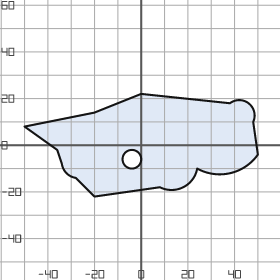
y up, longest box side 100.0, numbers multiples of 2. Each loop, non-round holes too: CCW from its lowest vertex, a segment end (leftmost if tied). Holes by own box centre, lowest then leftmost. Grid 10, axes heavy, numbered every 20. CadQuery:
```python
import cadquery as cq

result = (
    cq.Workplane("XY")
    .moveTo(-20.0, -22.0)
    .lineTo(8.0, -18.0)
    .threePointArc((18.0, -18.0), (24.0, -10.0))
    .threePointArc((38.0, -12.0), (50.0, -4.0))
    .lineTo(48.0, 10.0)
    .threePointArc((46.0, 18.0), (38.0, 18.0))
    .lineTo(0.0, 22.0)
    .lineTo(-20.0, 14.0)
    .lineTo(-50.0, 8.0)
    .lineTo(-36.0, -2.0)
    .lineTo(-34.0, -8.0)
    .threePointArc((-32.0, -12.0), (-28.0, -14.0))
    .close()
    .moveTo(-4.0, -6.0)
    .circle(4.0)
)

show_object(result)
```